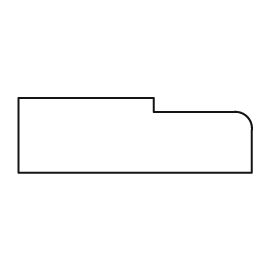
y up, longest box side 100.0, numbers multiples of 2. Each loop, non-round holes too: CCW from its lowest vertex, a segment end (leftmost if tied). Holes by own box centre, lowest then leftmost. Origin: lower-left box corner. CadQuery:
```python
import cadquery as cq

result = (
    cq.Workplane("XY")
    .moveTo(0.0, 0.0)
    .lineTo(100.0, 0.0)
    .lineTo(100.0, 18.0)
    .threePointArc((98.0, 24.0), (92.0, 26.0))
    .lineTo(58.0, 26.0)
    .lineTo(58.0, 32.0)
    .lineTo(0.0, 32.0)
    .close()
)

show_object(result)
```